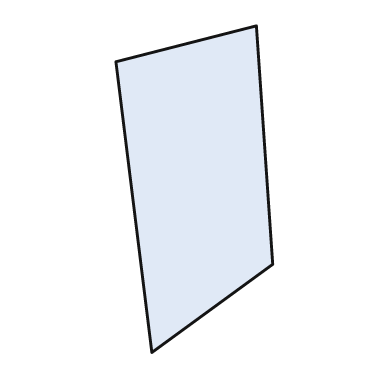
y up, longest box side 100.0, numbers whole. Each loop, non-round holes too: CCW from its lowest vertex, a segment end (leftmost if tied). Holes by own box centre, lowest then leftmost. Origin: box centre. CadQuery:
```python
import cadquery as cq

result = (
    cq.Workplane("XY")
    .moveTo(-13.0, -50.0)
    .lineTo(24.0, -23.0)
    .lineTo(19.0, 50.0)
    .lineTo(-24.0, 39.0)
    .close()
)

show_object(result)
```